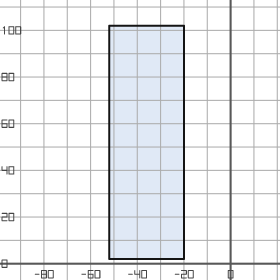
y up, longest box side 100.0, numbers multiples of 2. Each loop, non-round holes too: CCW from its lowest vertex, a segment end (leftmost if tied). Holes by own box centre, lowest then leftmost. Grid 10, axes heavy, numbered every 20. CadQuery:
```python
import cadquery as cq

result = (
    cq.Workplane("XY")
    .moveTo(-52.0, 2.0)
    .lineTo(-20.0, 2.0)
    .lineTo(-20.0, 102.0)
    .lineTo(-52.0, 102.0)
    .close()
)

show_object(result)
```